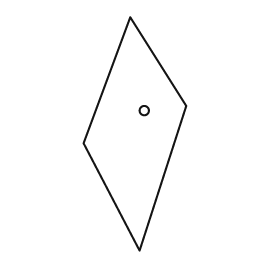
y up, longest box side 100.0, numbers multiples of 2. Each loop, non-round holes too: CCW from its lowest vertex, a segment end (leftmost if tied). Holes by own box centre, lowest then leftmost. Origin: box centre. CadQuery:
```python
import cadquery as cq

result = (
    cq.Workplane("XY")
    .moveTo(2.0, -50.0)
    .lineTo(22.0, 12.0)
    .lineTo(-2.0, 50.0)
    .lineTo(-22.0, -4.0)
    .close()
    .moveTo(4.0, 10.0)
    .circle(2.0)
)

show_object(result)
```